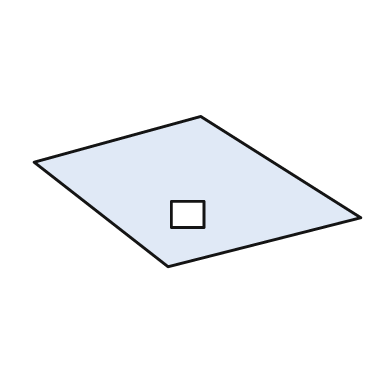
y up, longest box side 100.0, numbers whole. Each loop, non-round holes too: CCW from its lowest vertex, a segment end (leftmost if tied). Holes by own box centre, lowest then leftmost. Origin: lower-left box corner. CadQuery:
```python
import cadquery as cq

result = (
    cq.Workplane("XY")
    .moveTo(41.0, 0.0)
    .lineTo(100.0, 15.0)
    .lineTo(51.0, 46.0)
    .lineTo(0.0, 32.0)
    .close()
    .moveTo(42.0, 12.0)
    .lineTo(52.0, 12.0)
    .lineTo(52.0, 20.0)
    .lineTo(42.0, 20.0)
    .close()
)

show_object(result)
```